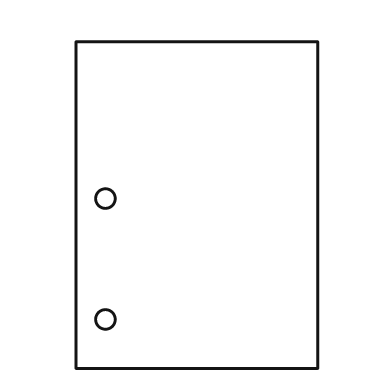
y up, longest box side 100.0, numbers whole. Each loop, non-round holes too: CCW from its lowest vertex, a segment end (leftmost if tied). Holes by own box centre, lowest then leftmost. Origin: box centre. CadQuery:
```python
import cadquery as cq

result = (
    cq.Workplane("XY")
    .moveTo(-37.0, -50.0)
    .lineTo(37.0, -50.0)
    .lineTo(37.0, 50.0)
    .lineTo(-37.0, 50.0)
    .close()
    .moveTo(-28.0, -35.0)
    .circle(3.0)
    .moveTo(-28.0, 2.0)
    .circle(3.0)
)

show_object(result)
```